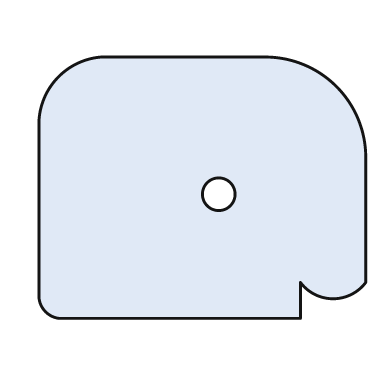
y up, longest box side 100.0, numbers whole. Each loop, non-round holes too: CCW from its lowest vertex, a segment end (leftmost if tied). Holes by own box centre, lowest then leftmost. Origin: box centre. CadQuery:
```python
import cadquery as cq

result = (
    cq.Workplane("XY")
    .moveTo(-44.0, -40.0)
    .lineTo(30.0, -40.0)
    .lineTo(30.0, -29.0)
    .threePointArc((40.0, -34.0), (50.0, -29.0))
    .lineTo(50.0, 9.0)
    .threePointArc((41.0, 31.0), (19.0, 40.0))
    .lineTo(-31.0, 40.0)
    .threePointArc((-44.0, 34.0), (-50.0, 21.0))
    .lineTo(-50.0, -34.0)
    .threePointArc((-48.0, -38.0), (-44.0, -40.0))
    .close()
    .moveTo(5.0, -2.0)
    .circle(5.0)
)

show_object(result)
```